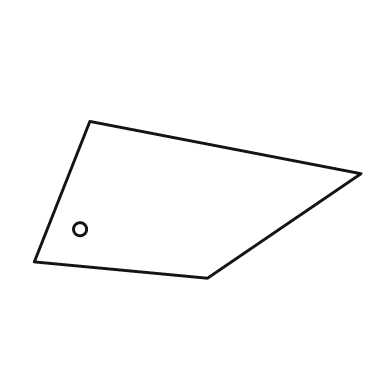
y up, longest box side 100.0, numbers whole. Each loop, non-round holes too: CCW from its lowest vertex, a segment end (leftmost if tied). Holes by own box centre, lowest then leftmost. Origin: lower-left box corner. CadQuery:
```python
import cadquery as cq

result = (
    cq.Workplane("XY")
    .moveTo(53.0, 0.0)
    .lineTo(100.0, 32.0)
    .lineTo(17.0, 48.0)
    .lineTo(0.0, 5.0)
    .close()
    .moveTo(14.0, 15.0)
    .circle(2.0)
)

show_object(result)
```